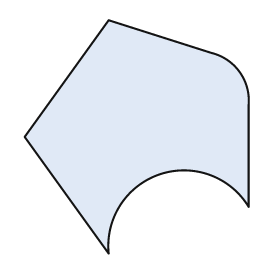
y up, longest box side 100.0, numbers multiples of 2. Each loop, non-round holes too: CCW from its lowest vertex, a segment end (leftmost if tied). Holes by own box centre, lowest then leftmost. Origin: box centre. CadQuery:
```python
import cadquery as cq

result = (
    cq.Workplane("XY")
    .moveTo(-12.0, -50.0)
    .threePointArc((10.0, -16.0), (48.0, -30.0))
    .lineTo(48.0, 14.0)
    .threePointArc((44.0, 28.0), (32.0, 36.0))
    .lineTo(-12.0, 50.0)
    .lineTo(-48.0, 0.0)
    .close()
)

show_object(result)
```